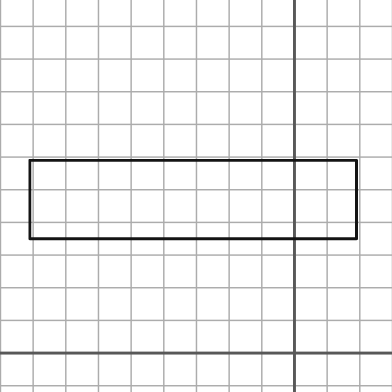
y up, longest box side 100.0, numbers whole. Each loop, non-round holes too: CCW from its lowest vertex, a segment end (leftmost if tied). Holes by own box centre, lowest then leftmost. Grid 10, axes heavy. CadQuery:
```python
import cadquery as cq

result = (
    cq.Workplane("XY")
    .moveTo(-81.0, 35.0)
    .lineTo(19.0, 35.0)
    .lineTo(19.0, 59.0)
    .lineTo(-81.0, 59.0)
    .close()
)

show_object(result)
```